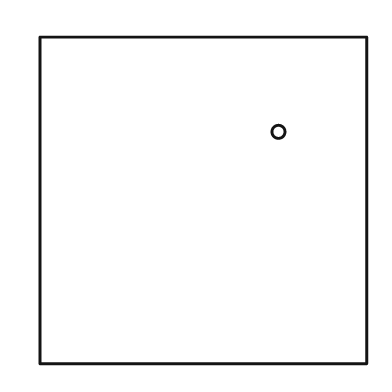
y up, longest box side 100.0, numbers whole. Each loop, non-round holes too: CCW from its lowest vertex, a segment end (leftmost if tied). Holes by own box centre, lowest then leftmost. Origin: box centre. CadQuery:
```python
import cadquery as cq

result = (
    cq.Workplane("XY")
    .moveTo(-50.0, -50.0)
    .lineTo(50.0, -50.0)
    .lineTo(50.0, 50.0)
    .lineTo(-50.0, 50.0)
    .close()
    .moveTo(23.0, 21.0)
    .circle(2.0)
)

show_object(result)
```